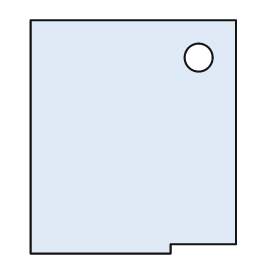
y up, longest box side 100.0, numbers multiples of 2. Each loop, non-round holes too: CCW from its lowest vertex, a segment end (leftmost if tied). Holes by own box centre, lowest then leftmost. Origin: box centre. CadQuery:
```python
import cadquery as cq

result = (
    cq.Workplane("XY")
    .moveTo(-44.0, -50.0)
    .lineTo(16.0, -50.0)
    .lineTo(16.0, -46.0)
    .lineTo(44.0, -46.0)
    .lineTo(44.0, 50.0)
    .lineTo(-44.0, 50.0)
    .close()
    .moveTo(28.0, 34.0)
    .circle(6.0)
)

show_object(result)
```